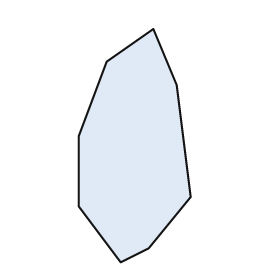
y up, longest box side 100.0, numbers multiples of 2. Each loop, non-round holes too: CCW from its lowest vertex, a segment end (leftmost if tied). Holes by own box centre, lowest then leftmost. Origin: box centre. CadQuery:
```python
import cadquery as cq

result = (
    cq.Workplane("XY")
    .moveTo(-6.0, -50.0)
    .lineTo(6.0, -44.0)
    .lineTo(24.0, -22.0)
    .lineTo(18.0, 26.0)
    .lineTo(8.0, 50.0)
    .lineTo(-12.0, 36.0)
    .lineTo(-24.0, 4.0)
    .lineTo(-24.0, -26.0)
    .close()
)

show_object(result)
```